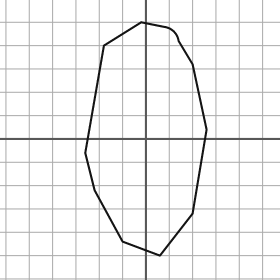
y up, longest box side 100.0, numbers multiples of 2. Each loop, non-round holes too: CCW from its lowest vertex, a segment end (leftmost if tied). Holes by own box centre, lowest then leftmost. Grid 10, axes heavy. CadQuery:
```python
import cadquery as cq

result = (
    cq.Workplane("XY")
    .moveTo(6.0, -50.0)
    .lineTo(20.0, -32.0)
    .lineTo(26.0, 4.0)
    .lineTo(20.0, 32.0)
    .lineTo(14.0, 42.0)
    .threePointArc((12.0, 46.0), (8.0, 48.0))
    .lineTo(-2.0, 50.0)
    .lineTo(-18.0, 40.0)
    .lineTo(-26.0, -6.0)
    .lineTo(-22.0, -22.0)
    .lineTo(-10.0, -44.0)
    .close()
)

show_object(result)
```